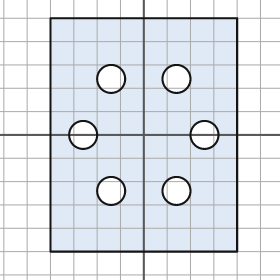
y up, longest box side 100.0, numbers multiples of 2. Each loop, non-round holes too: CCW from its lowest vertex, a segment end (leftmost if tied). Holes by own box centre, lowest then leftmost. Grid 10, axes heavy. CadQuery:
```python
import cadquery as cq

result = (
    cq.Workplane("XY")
    .moveTo(-40.0, -50.0)
    .lineTo(40.0, -50.0)
    .lineTo(40.0, 50.0)
    .lineTo(-40.0, 50.0)
    .close()
    .moveTo(-14.0, -24.0)
    .circle(6.0)
    .moveTo(14.0, -24.0)
    .circle(6.0)
    .moveTo(-26.0, 0.0)
    .circle(6.0)
    .moveTo(26.0, 0.0)
    .circle(6.0)
    .moveTo(-14.0, 24.0)
    .circle(6.0)
    .moveTo(14.0, 24.0)
    .circle(6.0)
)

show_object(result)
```